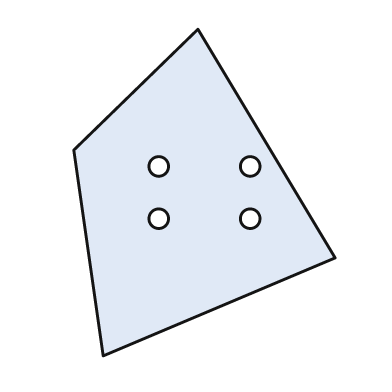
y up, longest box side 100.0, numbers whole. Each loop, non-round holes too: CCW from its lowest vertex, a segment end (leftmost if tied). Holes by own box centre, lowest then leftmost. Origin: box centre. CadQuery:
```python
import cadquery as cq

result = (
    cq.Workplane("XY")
    .moveTo(-31.0, -50.0)
    .lineTo(40.0, -20.0)
    .lineTo(-2.0, 50.0)
    .lineTo(-40.0, 13.0)
    .close()
    .moveTo(-14.0, -8.0)
    .circle(3.0)
    .moveTo(14.0, -8.0)
    .circle(3.0)
    .moveTo(-14.0, 8.0)
    .circle(3.0)
    .moveTo(14.0, 8.0)
    .circle(3.0)
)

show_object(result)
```